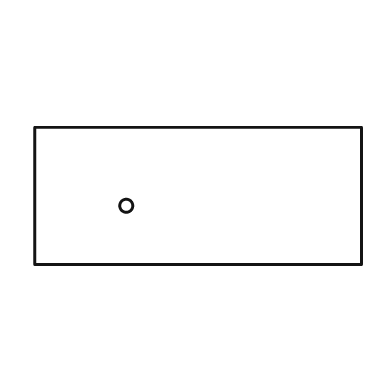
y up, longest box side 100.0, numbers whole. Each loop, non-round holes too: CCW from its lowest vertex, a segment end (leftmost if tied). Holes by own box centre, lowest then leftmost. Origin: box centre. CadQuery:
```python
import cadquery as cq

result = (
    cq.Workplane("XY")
    .moveTo(-50.0, -21.0)
    .lineTo(50.0, -21.0)
    .lineTo(50.0, 21.0)
    .lineTo(-50.0, 21.0)
    .close()
    .moveTo(-22.0, -3.0)
    .circle(2.0)
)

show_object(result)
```